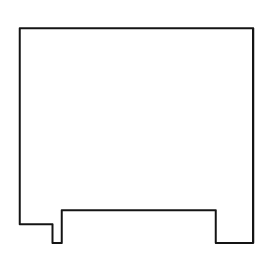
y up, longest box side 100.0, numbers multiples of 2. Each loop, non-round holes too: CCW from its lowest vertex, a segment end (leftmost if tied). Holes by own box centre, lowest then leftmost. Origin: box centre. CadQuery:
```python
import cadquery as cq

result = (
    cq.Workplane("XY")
    .moveTo(-36.0, -46.0)
    .lineTo(-32.0, -46.0)
    .lineTo(-32.0, -32.0)
    .lineTo(34.0, -32.0)
    .lineTo(34.0, -46.0)
    .lineTo(50.0, -46.0)
    .lineTo(50.0, 46.0)
    .lineTo(-50.0, 46.0)
    .lineTo(-50.0, -38.0)
    .lineTo(-36.0, -38.0)
    .close()
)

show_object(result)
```